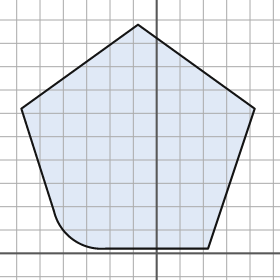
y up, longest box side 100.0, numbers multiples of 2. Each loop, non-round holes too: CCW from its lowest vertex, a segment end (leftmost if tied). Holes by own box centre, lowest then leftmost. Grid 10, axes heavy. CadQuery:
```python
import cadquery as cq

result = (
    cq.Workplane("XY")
    .moveTo(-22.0, 2.0)
    .lineTo(22.0, 2.0)
    .lineTo(42.0, 62.0)
    .lineTo(-8.0, 98.0)
    .lineTo(-58.0, 62.0)
    .lineTo(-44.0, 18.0)
    .threePointArc((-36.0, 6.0), (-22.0, 2.0))
    .close()
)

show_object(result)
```